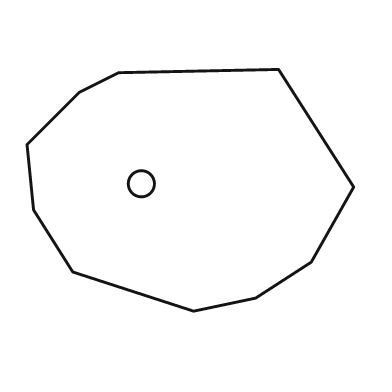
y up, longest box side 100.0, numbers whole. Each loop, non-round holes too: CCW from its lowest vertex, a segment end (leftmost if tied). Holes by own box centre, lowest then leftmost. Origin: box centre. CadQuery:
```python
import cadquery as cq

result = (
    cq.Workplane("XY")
    .moveTo(1.0, -37.0)
    .lineTo(20.0, -33.0)
    .lineTo(37.0, -22.0)
    .lineTo(50.0, 1.0)
    .lineTo(27.0, 37.0)
    .lineTo(-22.0, 36.0)
    .lineTo(-34.0, 30.0)
    .lineTo(-50.0, 14.0)
    .lineTo(-48.0, -6.0)
    .lineTo(-36.0, -25.0)
    .close()
    .moveTo(-15.0, 2.0)
    .circle(4.0)
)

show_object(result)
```